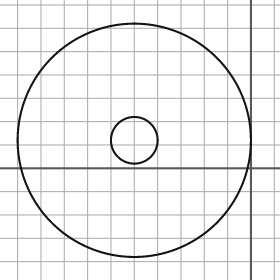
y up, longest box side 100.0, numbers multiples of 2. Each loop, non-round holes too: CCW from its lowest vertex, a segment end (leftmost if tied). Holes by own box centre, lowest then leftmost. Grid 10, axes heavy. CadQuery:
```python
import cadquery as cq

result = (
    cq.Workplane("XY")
    .moveTo(-50.0, 12.0)
    .circle(50.0)
    .moveTo(-50.0, 12.0)
    .circle(10.0)
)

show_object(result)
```